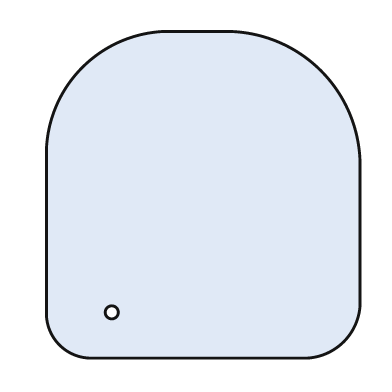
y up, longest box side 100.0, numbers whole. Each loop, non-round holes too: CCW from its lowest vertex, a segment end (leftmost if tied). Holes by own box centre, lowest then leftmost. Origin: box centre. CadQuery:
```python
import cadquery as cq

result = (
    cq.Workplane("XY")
    .moveTo(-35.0, -50.0)
    .lineTo(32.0, -50.0)
    .threePointArc((43.0, -45.0), (48.0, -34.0))
    .lineTo(48.0, 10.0)
    .threePointArc((36.0, 38.0), (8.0, 50.0))
    .lineTo(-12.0, 50.0)
    .threePointArc((-37.0, 39.0), (-48.0, 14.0))
    .lineTo(-48.0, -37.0)
    .threePointArc((-44.0, -46.0), (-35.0, -50.0))
    .close()
    .moveTo(-28.0, -36.0)
    .circle(2.0)
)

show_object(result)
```